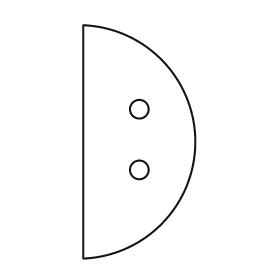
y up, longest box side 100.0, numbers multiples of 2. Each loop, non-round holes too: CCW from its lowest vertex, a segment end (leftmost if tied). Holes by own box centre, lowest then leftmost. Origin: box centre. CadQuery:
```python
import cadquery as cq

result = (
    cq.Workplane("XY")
    .moveTo(-24.0, -50.0)
    .threePointArc((24.0, 0.0), (-24.0, 50.0))
    .close()
    .moveTo(0.0, -12.0)
    .circle(4.0)
    .moveTo(0.0, 14.0)
    .circle(4.0)
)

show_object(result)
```